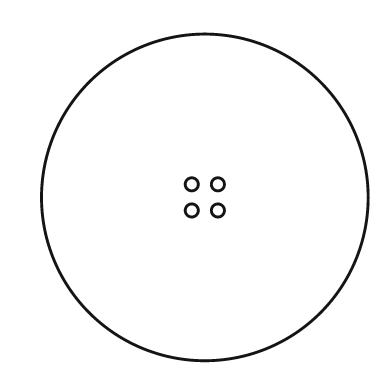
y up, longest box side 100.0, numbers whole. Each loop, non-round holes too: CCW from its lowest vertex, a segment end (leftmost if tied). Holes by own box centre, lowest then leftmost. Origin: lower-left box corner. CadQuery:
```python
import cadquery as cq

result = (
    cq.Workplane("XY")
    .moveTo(50.0, 50.0)
    .circle(50.0)
    .moveTo(46.0, 46.0)
    .circle(2.0)
    .moveTo(54.0, 46.0)
    .circle(2.0)
    .moveTo(46.0, 54.0)
    .circle(2.0)
    .moveTo(54.0, 54.0)
    .circle(2.0)
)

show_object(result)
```